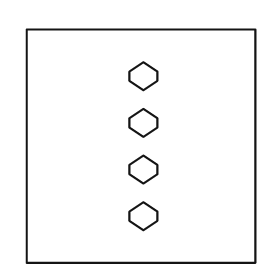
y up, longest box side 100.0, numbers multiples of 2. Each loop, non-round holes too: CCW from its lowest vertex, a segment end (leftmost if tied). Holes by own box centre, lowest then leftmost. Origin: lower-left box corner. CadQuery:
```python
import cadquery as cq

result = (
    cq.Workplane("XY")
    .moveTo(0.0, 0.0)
    .lineTo(98.0, 0.0)
    .lineTo(98.0, 100.0)
    .lineTo(0.0, 100.0)
    .close()
    .moveTo(50.0, 14.0)
    .lineTo(56.0, 18.0)
    .lineTo(56.0, 22.0)
    .lineTo(50.0, 26.0)
    .lineTo(44.0, 22.0)
    .lineTo(44.0, 18.0)
    .close()
    .moveTo(50.0, 34.0)
    .lineTo(56.0, 38.0)
    .lineTo(56.0, 42.0)
    .lineTo(50.0, 46.0)
    .lineTo(44.0, 42.0)
    .lineTo(44.0, 38.0)
    .close()
    .moveTo(50.0, 54.0)
    .lineTo(56.0, 58.0)
    .lineTo(56.0, 62.0)
    .lineTo(50.0, 66.0)
    .lineTo(44.0, 62.0)
    .lineTo(44.0, 58.0)
    .close()
    .moveTo(50.0, 74.0)
    .lineTo(56.0, 78.0)
    .lineTo(56.0, 82.0)
    .lineTo(50.0, 86.0)
    .lineTo(44.0, 82.0)
    .lineTo(44.0, 78.0)
    .close()
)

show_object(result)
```